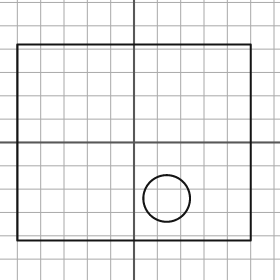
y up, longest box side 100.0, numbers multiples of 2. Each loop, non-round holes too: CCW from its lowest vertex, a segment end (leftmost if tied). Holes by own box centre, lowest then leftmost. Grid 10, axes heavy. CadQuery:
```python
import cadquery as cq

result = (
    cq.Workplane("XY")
    .moveTo(-50.0, -42.0)
    .lineTo(50.0, -42.0)
    .lineTo(50.0, 42.0)
    .lineTo(-50.0, 42.0)
    .close()
    .moveTo(14.0, -24.0)
    .circle(10.0)
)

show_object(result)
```